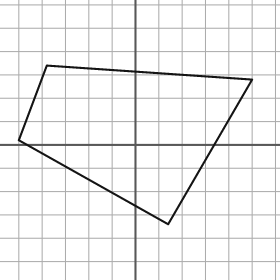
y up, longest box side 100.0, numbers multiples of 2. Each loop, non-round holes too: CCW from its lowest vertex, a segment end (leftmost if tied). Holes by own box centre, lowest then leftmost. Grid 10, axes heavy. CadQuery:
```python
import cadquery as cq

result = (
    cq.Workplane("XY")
    .moveTo(14.0, -34.0)
    .lineTo(50.0, 28.0)
    .lineTo(-38.0, 34.0)
    .lineTo(-50.0, 2.0)
    .close()
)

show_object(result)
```